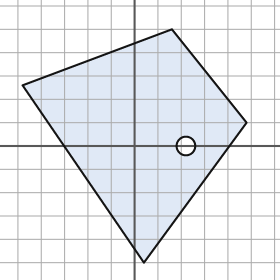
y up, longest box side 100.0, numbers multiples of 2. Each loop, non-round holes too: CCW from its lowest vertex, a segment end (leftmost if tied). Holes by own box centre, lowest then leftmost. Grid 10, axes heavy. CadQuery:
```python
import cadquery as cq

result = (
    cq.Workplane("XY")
    .moveTo(4.0, -50.0)
    .lineTo(48.0, 10.0)
    .lineTo(16.0, 50.0)
    .lineTo(-48.0, 26.0)
    .close()
    .moveTo(22.0, 0.0)
    .circle(4.0)
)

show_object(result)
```